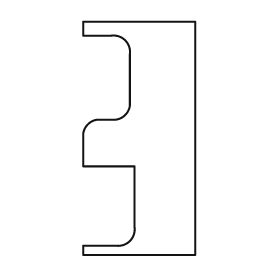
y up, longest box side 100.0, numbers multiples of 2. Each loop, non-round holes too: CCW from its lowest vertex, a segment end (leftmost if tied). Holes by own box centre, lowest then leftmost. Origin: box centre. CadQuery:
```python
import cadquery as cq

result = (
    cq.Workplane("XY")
    .moveTo(-24.0, -50.0)
    .lineTo(24.0, -50.0)
    .lineTo(24.0, 50.0)
    .lineTo(-24.0, 50.0)
    .lineTo(-24.0, 44.0)
    .lineTo(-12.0, 44.0)
    .threePointArc((-6.0, 42.0), (-4.0, 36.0))
    .lineTo(-4.0, 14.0)
    .threePointArc((-6.0, 10.0), (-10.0, 8.0))
    .lineTo(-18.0, 8.0)
    .threePointArc((-22.0, 6.0), (-24.0, 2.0))
    .lineTo(-24.0, -12.0)
    .lineTo(-2.0, -12.0)
    .lineTo(-2.0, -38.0)
    .threePointArc((-4.0, -44.0), (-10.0, -46.0))
    .lineTo(-24.0, -46.0)
    .close()
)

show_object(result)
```